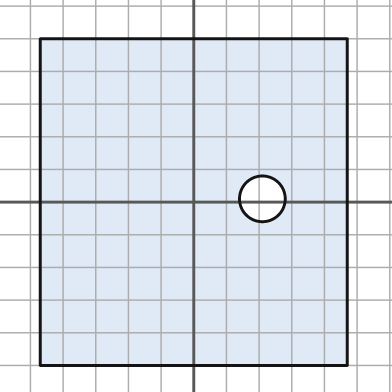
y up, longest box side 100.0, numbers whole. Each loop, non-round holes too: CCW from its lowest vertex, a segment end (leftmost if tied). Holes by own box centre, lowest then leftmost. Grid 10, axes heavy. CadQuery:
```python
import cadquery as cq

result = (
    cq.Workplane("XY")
    .moveTo(-47.0, -50.0)
    .lineTo(47.0, -50.0)
    .lineTo(47.0, 50.0)
    .lineTo(-47.0, 50.0)
    .close()
    .moveTo(21.0, 1.0)
    .circle(7.0)
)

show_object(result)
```